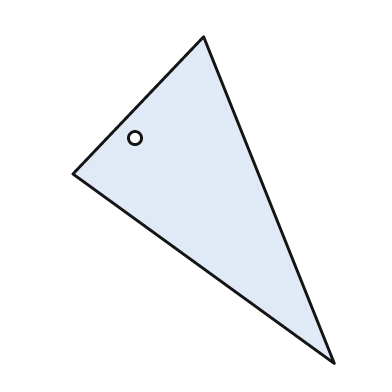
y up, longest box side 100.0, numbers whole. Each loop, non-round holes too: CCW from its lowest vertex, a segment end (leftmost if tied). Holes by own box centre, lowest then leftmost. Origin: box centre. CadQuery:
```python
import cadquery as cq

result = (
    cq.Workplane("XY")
    .moveTo(40.0, -50.0)
    .lineTo(0.0, 50.0)
    .lineTo(-40.0, 8.0)
    .close()
    .moveTo(-21.0, 19.0)
    .circle(2.0)
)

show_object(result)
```